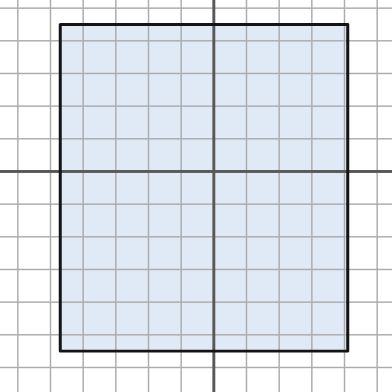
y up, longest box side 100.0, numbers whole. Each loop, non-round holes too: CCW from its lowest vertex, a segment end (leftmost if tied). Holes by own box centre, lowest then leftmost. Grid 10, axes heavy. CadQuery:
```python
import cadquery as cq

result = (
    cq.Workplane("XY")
    .moveTo(-47.0, -55.0)
    .lineTo(41.0, -55.0)
    .lineTo(41.0, 45.0)
    .lineTo(-47.0, 45.0)
    .close()
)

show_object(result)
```